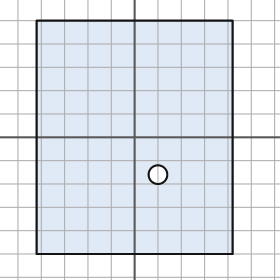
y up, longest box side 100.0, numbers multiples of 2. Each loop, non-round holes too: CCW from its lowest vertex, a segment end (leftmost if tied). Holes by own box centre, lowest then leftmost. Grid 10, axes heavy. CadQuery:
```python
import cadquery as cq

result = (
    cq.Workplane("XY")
    .moveTo(-42.0, -50.0)
    .lineTo(42.0, -50.0)
    .lineTo(42.0, 50.0)
    .lineTo(-42.0, 50.0)
    .close()
    .moveTo(10.0, -16.0)
    .circle(4.0)
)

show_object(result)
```